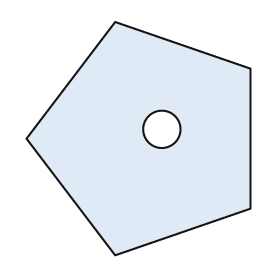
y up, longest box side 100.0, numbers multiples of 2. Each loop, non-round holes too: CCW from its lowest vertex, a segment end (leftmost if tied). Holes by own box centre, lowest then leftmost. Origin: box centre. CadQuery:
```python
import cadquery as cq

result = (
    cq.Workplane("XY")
    .moveTo(-10.0, -50.0)
    .lineTo(48.0, -30.0)
    .lineTo(48.0, 30.0)
    .lineTo(-10.0, 50.0)
    .lineTo(-48.0, 0.0)
    .close()
    .moveTo(10.0, 4.0)
    .circle(8.0)
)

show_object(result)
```